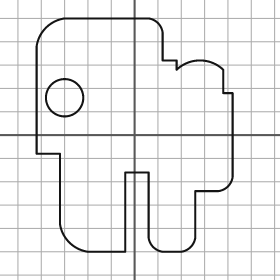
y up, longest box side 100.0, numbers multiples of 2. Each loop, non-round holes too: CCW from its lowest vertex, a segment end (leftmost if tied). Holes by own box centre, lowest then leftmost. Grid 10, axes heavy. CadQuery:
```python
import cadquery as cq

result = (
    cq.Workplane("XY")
    .moveTo(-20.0, -50.0)
    .lineTo(-4.0, -50.0)
    .lineTo(-4.0, -16.0)
    .lineTo(6.0, -16.0)
    .lineTo(6.0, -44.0)
    .threePointArc((8.0, -48.0), (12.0, -50.0))
    .lineTo(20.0, -50.0)
    .threePointArc((24.0, -48.0), (26.0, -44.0))
    .lineTo(26.0, -24.0)
    .lineTo(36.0, -24.0)
    .threePointArc((40.0, -22.0), (42.0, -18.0))
    .lineTo(42.0, 18.0)
    .lineTo(38.0, 18.0)
    .lineTo(38.0, 28.0)
    .threePointArc((28.0, 32.0), (18.0, 28.0))
    .lineTo(18.0, 32.0)
    .lineTo(12.0, 32.0)
    .lineTo(12.0, 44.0)
    .threePointArc((10.0, 48.0), (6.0, 50.0))
    .lineTo(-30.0, 50.0)
    .threePointArc((-38.0, 46.0), (-42.0, 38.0))
    .lineTo(-42.0, -8.0)
    .lineTo(-32.0, -8.0)
    .lineTo(-32.0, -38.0)
    .threePointArc((-28.0, -46.0), (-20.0, -50.0))
    .close()
    .moveTo(-30.0, 16.0)
    .circle(8.0)
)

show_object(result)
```